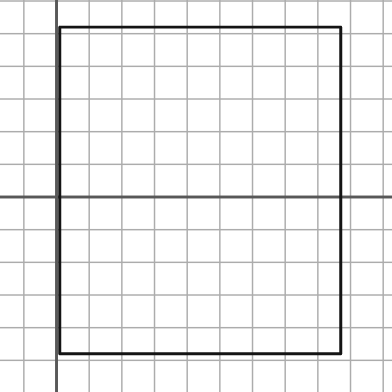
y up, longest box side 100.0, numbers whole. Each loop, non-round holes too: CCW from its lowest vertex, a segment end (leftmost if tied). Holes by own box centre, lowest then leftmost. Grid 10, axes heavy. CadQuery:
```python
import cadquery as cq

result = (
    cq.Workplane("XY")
    .moveTo(1.0, -48.0)
    .lineTo(87.0, -48.0)
    .lineTo(87.0, 52.0)
    .lineTo(1.0, 52.0)
    .close()
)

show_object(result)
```